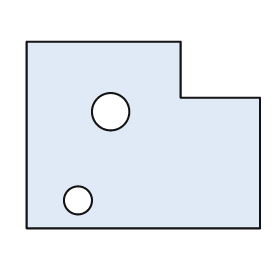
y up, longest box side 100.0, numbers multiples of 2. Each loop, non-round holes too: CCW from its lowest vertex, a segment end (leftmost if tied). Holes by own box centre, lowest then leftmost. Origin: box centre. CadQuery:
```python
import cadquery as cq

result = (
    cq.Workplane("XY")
    .moveTo(-50.0, -40.0)
    .lineTo(50.0, -40.0)
    .lineTo(50.0, 16.0)
    .lineTo(16.0, 16.0)
    .lineTo(16.0, 40.0)
    .lineTo(-50.0, 40.0)
    .close()
    .moveTo(-28.0, -28.0)
    .circle(6.0)
    .moveTo(-14.0, 10.0)
    .circle(8.0)
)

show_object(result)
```